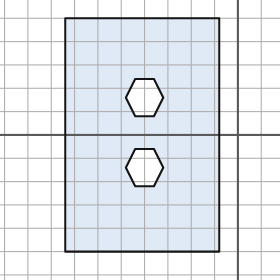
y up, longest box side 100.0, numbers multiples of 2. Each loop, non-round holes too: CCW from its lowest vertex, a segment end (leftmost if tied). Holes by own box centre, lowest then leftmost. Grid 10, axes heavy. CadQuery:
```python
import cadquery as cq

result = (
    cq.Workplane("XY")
    .moveTo(-74.0, -50.0)
    .lineTo(-8.0, -50.0)
    .lineTo(-8.0, 50.0)
    .lineTo(-74.0, 50.0)
    .close()
    .moveTo(-44.0, -22.0)
    .lineTo(-36.0, -22.0)
    .lineTo(-32.0, -14.0)
    .lineTo(-36.0, -6.0)
    .lineTo(-44.0, -6.0)
    .lineTo(-48.0, -14.0)
    .close()
    .moveTo(-44.0, 8.0)
    .lineTo(-36.0, 8.0)
    .lineTo(-32.0, 16.0)
    .lineTo(-36.0, 24.0)
    .lineTo(-44.0, 24.0)
    .lineTo(-48.0, 16.0)
    .close()
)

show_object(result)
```